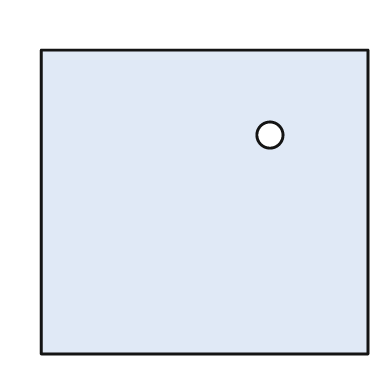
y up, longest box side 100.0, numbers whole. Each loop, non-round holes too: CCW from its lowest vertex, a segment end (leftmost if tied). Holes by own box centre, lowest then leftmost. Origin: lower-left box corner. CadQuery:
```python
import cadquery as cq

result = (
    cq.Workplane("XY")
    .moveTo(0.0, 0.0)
    .lineTo(100.0, 0.0)
    .lineTo(100.0, 93.0)
    .lineTo(0.0, 93.0)
    .close()
    .moveTo(70.0, 67.0)
    .circle(4.0)
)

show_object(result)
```